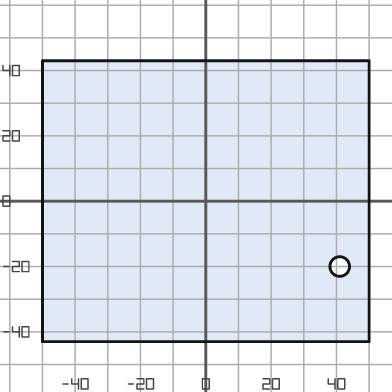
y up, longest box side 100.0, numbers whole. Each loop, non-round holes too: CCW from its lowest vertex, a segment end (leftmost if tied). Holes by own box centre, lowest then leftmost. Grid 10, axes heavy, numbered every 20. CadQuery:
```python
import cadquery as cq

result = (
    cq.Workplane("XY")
    .moveTo(-50.0, -43.0)
    .lineTo(50.0, -43.0)
    .lineTo(50.0, 43.0)
    .lineTo(-50.0, 43.0)
    .close()
    .moveTo(41.0, -20.0)
    .circle(3.0)
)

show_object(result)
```